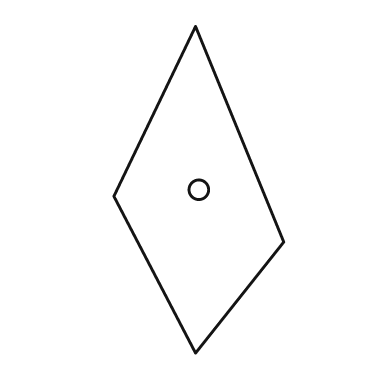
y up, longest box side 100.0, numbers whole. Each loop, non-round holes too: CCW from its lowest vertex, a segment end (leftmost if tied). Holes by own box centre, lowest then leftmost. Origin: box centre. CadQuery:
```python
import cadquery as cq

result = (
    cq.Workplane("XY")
    .moveTo(-1.0, -50.0)
    .lineTo(26.0, -16.0)
    .lineTo(-1.0, 50.0)
    .lineTo(-26.0, -2.0)
    .close()
    .moveTo(0.0, 0.0)
    .circle(3.0)
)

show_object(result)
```